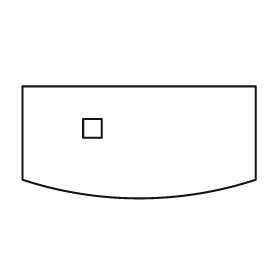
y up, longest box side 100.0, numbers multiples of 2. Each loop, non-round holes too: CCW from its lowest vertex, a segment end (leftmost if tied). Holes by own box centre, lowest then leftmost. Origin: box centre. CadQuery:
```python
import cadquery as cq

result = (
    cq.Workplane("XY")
    .moveTo(-50.0, -16.0)
    .threePointArc((0.0, -24.0), (50.0, -16.0))
    .lineTo(50.0, 24.0)
    .lineTo(-50.0, 24.0)
    .close()
    .moveTo(-24.0, 2.0)
    .lineTo(-16.0, 2.0)
    .lineTo(-16.0, 10.0)
    .lineTo(-24.0, 10.0)
    .close()
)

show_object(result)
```